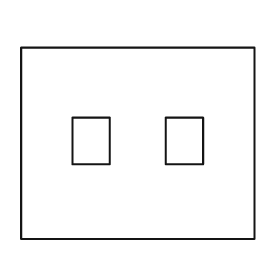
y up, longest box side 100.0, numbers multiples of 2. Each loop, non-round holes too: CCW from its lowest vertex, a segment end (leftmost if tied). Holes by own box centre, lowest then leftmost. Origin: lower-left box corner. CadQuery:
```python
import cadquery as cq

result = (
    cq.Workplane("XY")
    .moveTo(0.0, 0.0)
    .lineTo(100.0, 0.0)
    .lineTo(100.0, 82.0)
    .lineTo(0.0, 82.0)
    .close()
    .moveTo(22.0, 32.0)
    .lineTo(38.0, 32.0)
    .lineTo(38.0, 52.0)
    .lineTo(22.0, 52.0)
    .close()
    .moveTo(62.0, 32.0)
    .lineTo(78.0, 32.0)
    .lineTo(78.0, 52.0)
    .lineTo(62.0, 52.0)
    .close()
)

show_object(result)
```